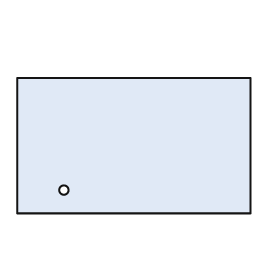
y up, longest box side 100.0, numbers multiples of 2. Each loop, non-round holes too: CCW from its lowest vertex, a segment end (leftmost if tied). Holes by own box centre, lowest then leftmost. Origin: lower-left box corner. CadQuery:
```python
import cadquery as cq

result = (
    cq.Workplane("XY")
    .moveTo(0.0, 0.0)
    .lineTo(100.0, 0.0)
    .lineTo(100.0, 58.0)
    .lineTo(0.0, 58.0)
    .close()
    .moveTo(20.0, 10.0)
    .circle(2.0)
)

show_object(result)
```